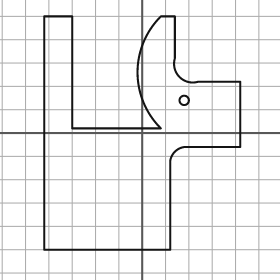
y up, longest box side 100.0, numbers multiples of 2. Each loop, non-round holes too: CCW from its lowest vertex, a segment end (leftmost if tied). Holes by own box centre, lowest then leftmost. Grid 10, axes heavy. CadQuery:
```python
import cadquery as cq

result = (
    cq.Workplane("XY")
    .moveTo(-42.0, -50.0)
    .lineTo(12.0, -50.0)
    .lineTo(12.0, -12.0)
    .threePointArc((14.0, -8.0), (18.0, -6.0))
    .lineTo(42.0, -6.0)
    .lineTo(42.0, 22.0)
    .lineTo(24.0, 22.0)
    .threePointArc((16.0, 24.0), (14.0, 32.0))
    .lineTo(14.0, 50.0)
    .lineTo(8.0, 50.0)
    .threePointArc((-2.0, 26.0), (8.0, 2.0))
    .lineTo(-30.0, 2.0)
    .lineTo(-30.0, 50.0)
    .lineTo(-42.0, 50.0)
    .close()
    .moveTo(18.0, 14.0)
    .circle(2.0)
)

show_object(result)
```